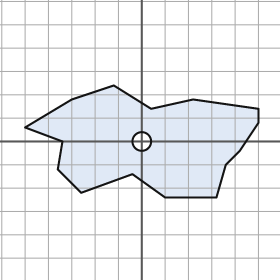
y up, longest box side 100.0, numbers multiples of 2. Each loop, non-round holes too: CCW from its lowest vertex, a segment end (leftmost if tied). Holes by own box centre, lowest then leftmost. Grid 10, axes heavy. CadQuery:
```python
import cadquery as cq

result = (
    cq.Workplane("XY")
    .moveTo(10.0, -24.0)
    .lineTo(32.0, -24.0)
    .lineTo(36.0, -10.0)
    .lineTo(42.0, -4.0)
    .lineTo(50.0, 8.0)
    .lineTo(50.0, 14.0)
    .lineTo(22.0, 18.0)
    .lineTo(4.0, 14.0)
    .lineTo(-12.0, 24.0)
    .lineTo(-30.0, 18.0)
    .lineTo(-50.0, 6.0)
    .lineTo(-34.0, 0.0)
    .lineTo(-36.0, -12.0)
    .lineTo(-26.0, -22.0)
    .lineTo(-4.0, -14.0)
    .close()
    .moveTo(0.0, 0.0)
    .circle(4.0)
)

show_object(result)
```